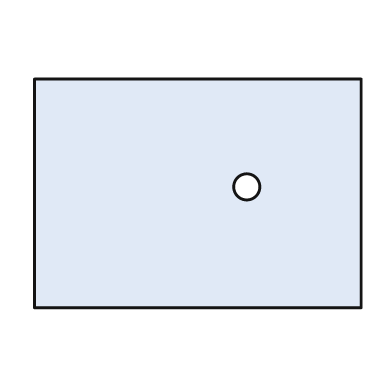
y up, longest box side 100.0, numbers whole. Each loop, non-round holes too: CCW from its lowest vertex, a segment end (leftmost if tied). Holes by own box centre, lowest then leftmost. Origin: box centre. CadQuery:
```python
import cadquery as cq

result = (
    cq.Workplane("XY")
    .moveTo(-50.0, -35.0)
    .lineTo(50.0, -35.0)
    .lineTo(50.0, 35.0)
    .lineTo(-50.0, 35.0)
    .close()
    .moveTo(15.0, 2.0)
    .circle(4.0)
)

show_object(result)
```